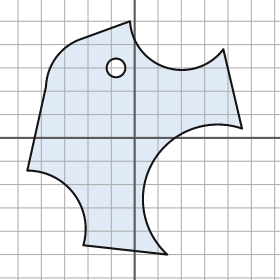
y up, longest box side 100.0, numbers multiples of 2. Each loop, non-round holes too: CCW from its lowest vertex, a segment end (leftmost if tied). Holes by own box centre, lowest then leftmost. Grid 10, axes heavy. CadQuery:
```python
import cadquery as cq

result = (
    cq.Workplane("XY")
    .moveTo(14.0, -50.0)
    .threePointArc((8.0, -10.0), (46.0, 4.0))
    .lineTo(38.0, 38.0)
    .threePointArc((14.0, 30.0), (-2.0, 50.0))
    .lineTo(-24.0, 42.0)
    .threePointArc((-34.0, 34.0), (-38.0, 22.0))
    .lineTo(-46.0, -14.0)
    .threePointArc((-26.0, -24.0), (-22.0, -46.0))
    .close()
    .moveTo(-8.0, 30.0)
    .circle(4.0)
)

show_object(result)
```